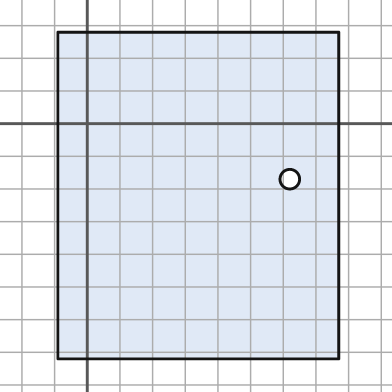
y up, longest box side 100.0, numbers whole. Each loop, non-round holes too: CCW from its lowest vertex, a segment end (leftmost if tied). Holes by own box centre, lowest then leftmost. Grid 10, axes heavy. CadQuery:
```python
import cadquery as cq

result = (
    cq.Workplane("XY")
    .moveTo(-9.0, -72.0)
    .lineTo(77.0, -72.0)
    .lineTo(77.0, 28.0)
    .lineTo(-9.0, 28.0)
    .close()
    .moveTo(62.0, -17.0)
    .circle(3.0)
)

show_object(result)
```